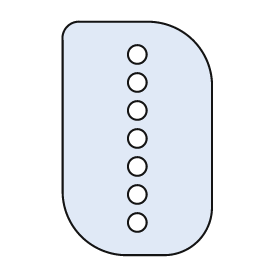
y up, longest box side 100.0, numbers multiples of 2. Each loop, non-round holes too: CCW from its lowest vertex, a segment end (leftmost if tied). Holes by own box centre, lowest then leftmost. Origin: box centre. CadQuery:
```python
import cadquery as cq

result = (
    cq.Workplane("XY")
    .moveTo(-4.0, -50.0)
    .lineTo(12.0, -50.0)
    .threePointArc((26.0, -44.0), (32.0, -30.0))
    .lineTo(32.0, 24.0)
    .threePointArc((24.0, 42.0), (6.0, 50.0))
    .lineTo(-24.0, 50.0)
    .threePointArc((-30.0, 48.0), (-32.0, 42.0))
    .lineTo(-32.0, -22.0)
    .threePointArc((-24.0, -42.0), (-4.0, -50.0))
    .close()
    .moveTo(0.0, -36.0)
    .circle(4.0)
    .moveTo(0.0, -24.0)
    .circle(4.0)
    .moveTo(0.0, -12.0)
    .circle(4.0)
    .moveTo(0.0, 0.0)
    .circle(4.0)
    .moveTo(0.0, 12.0)
    .circle(4.0)
    .moveTo(0.0, 24.0)
    .circle(4.0)
    .moveTo(0.0, 36.0)
    .circle(4.0)
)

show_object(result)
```